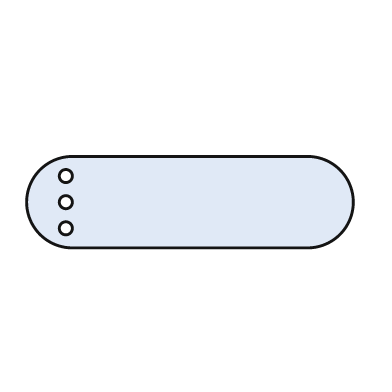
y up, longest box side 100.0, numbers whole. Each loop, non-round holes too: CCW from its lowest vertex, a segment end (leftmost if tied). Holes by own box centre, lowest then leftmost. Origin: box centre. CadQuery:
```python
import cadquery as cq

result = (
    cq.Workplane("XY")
    .moveTo(-36.0, -14.0)
    .lineTo(36.0, -14.0)
    .threePointArc((50.0, 0.0), (36.0, 14.0))
    .lineTo(-36.0, 14.0)
    .threePointArc((-50.0, 0.0), (-36.0, -14.0))
    .close()
    .moveTo(-38.0, -8.0)
    .circle(2.0)
    .moveTo(-38.0, 0.0)
    .circle(2.0)
    .moveTo(-38.0, 8.0)
    .circle(2.0)
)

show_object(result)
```